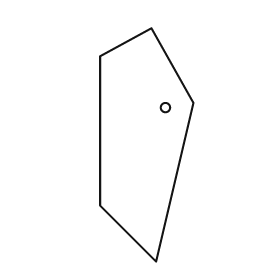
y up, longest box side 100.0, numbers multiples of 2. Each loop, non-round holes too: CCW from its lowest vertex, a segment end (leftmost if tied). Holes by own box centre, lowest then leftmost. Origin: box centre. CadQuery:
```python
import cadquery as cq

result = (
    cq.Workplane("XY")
    .moveTo(4.0, -50.0)
    .lineTo(20.0, 18.0)
    .lineTo(2.0, 50.0)
    .lineTo(-20.0, 38.0)
    .lineTo(-20.0, -26.0)
    .close()
    .moveTo(8.0, 16.0)
    .circle(2.0)
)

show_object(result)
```